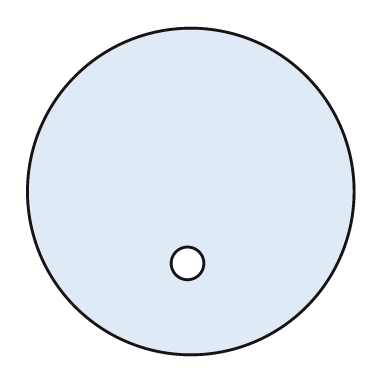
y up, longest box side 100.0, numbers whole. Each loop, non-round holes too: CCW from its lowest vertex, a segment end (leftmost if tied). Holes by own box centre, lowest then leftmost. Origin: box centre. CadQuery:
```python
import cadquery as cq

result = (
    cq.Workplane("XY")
    .moveTo(0.0, 0.0)
    .circle(50.0)
    .moveTo(-1.0, -22.0)
    .circle(5.0)
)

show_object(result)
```